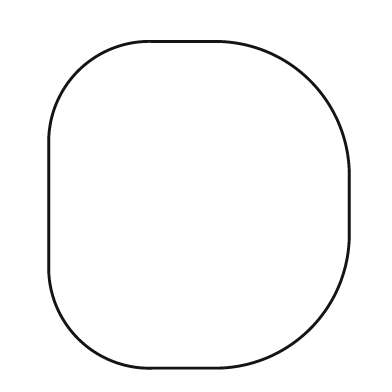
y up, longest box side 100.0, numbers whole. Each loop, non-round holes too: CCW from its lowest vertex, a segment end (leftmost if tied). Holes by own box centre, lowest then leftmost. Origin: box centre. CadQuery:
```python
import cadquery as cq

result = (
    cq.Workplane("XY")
    .moveTo(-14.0, -50.0)
    .lineTo(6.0, -50.0)
    .threePointArc((34.0, -38.0), (46.0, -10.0))
    .lineTo(46.0, 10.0)
    .threePointArc((34.0, 38.0), (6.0, 50.0))
    .lineTo(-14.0, 50.0)
    .threePointArc((-37.0, 41.0), (-46.0, 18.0))
    .lineTo(-46.0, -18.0)
    .threePointArc((-37.0, -41.0), (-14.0, -50.0))
    .close()
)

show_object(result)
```